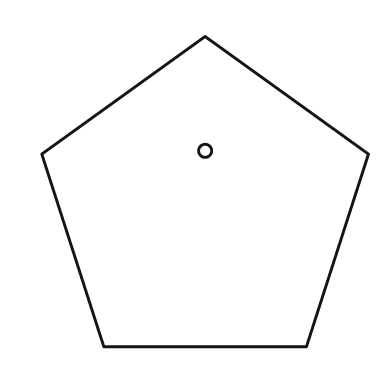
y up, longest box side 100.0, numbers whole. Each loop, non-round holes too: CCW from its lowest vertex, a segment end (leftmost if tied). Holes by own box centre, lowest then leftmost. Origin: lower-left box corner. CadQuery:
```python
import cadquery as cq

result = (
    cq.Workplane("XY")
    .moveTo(19.0, 0.0)
    .lineTo(81.0, 0.0)
    .lineTo(100.0, 59.0)
    .lineTo(50.0, 95.0)
    .lineTo(0.0, 59.0)
    .close()
    .moveTo(50.0, 60.0)
    .circle(2.0)
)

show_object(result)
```